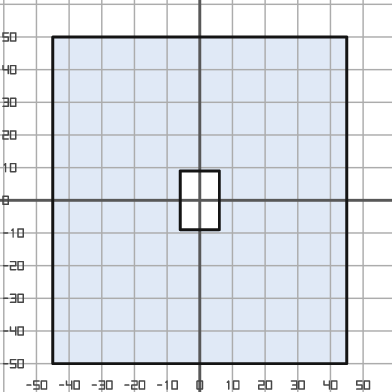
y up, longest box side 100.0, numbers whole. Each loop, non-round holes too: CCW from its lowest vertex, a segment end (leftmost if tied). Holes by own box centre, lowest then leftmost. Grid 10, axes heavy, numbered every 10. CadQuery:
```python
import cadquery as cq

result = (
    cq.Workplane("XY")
    .moveTo(-45.0, -50.0)
    .lineTo(45.0, -50.0)
    .lineTo(45.0, 50.0)
    .lineTo(-45.0, 50.0)
    .close()
    .moveTo(-6.0, -9.0)
    .lineTo(6.0, -9.0)
    .lineTo(6.0, 9.0)
    .lineTo(-6.0, 9.0)
    .close()
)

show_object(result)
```